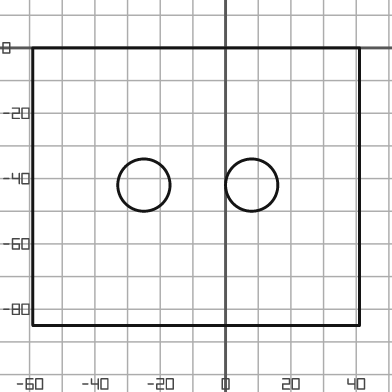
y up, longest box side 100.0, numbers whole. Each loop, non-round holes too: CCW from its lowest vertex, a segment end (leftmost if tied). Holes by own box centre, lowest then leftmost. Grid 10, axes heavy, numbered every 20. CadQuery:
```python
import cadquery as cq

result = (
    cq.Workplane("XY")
    .moveTo(-59.0, -85.0)
    .lineTo(41.0, -85.0)
    .lineTo(41.0, 0.0)
    .lineTo(-59.0, 0.0)
    .close()
    .moveTo(-25.0, -42.0)
    .circle(8.0)
    .moveTo(8.0, -42.0)
    .circle(8.0)
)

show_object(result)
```